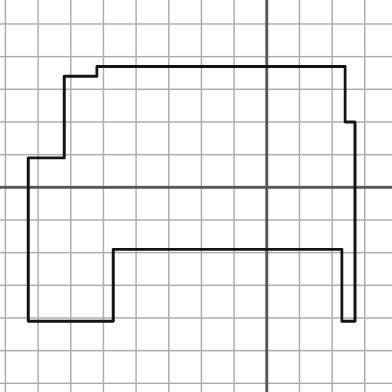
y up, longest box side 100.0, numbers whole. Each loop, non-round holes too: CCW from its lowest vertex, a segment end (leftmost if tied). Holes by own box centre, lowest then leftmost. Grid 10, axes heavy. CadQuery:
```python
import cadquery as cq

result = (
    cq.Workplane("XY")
    .moveTo(-73.0, -41.0)
    .lineTo(-47.0, -41.0)
    .lineTo(-47.0, -19.0)
    .lineTo(23.0, -19.0)
    .lineTo(23.0, -41.0)
    .lineTo(27.0, -41.0)
    .lineTo(27.0, 20.0)
    .lineTo(24.0, 20.0)
    .lineTo(24.0, 37.0)
    .lineTo(-52.0, 37.0)
    .lineTo(-52.0, 34.0)
    .lineTo(-62.0, 34.0)
    .lineTo(-62.0, 9.0)
    .lineTo(-73.0, 9.0)
    .close()
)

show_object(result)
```